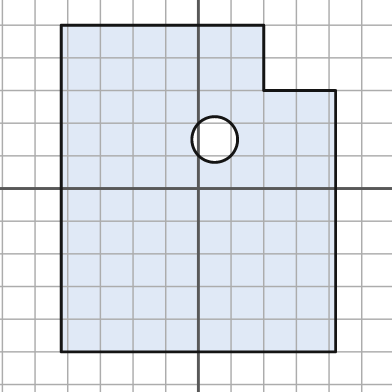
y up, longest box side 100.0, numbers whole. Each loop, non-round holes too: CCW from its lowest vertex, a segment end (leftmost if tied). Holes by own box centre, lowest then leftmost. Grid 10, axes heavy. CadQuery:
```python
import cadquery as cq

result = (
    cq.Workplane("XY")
    .moveTo(-42.0, -50.0)
    .lineTo(42.0, -50.0)
    .lineTo(42.0, 30.0)
    .lineTo(20.0, 30.0)
    .lineTo(20.0, 50.0)
    .lineTo(-42.0, 50.0)
    .close()
    .moveTo(5.0, 15.0)
    .circle(7.0)
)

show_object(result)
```